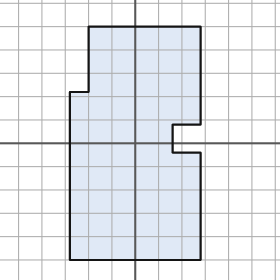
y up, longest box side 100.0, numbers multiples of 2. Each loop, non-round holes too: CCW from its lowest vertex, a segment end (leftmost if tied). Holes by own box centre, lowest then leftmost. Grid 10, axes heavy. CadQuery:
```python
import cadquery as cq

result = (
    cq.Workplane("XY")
    .moveTo(-28.0, -50.0)
    .lineTo(28.0, -50.0)
    .lineTo(28.0, -4.0)
    .lineTo(16.0, -4.0)
    .lineTo(16.0, 8.0)
    .lineTo(28.0, 8.0)
    .lineTo(28.0, 50.0)
    .lineTo(-20.0, 50.0)
    .lineTo(-20.0, 22.0)
    .lineTo(-28.0, 22.0)
    .close()
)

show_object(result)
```